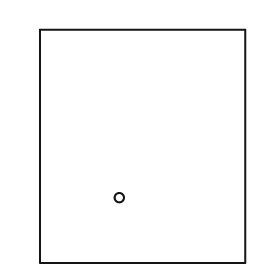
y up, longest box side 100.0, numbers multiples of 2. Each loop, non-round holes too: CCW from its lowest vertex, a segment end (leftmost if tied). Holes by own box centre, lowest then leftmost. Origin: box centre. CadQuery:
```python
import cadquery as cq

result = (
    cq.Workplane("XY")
    .moveTo(-44.0, -50.0)
    .lineTo(44.0, -50.0)
    .lineTo(44.0, 50.0)
    .lineTo(-44.0, 50.0)
    .close()
    .moveTo(-10.0, -22.0)
    .circle(2.0)
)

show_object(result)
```